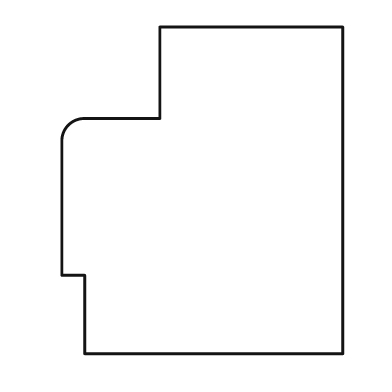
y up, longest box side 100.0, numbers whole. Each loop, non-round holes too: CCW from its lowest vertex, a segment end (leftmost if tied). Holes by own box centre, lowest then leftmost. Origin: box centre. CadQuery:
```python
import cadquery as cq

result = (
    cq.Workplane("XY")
    .moveTo(-36.0, -50.0)
    .lineTo(43.0, -50.0)
    .lineTo(43.0, 50.0)
    .lineTo(-13.0, 50.0)
    .lineTo(-13.0, 22.0)
    .lineTo(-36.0, 22.0)
    .threePointArc((-41.0, 20.0), (-43.0, 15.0))
    .lineTo(-43.0, -26.0)
    .lineTo(-36.0, -26.0)
    .close()
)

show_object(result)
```